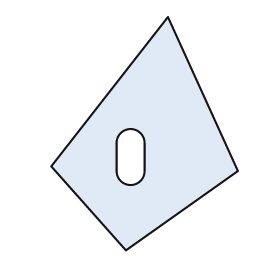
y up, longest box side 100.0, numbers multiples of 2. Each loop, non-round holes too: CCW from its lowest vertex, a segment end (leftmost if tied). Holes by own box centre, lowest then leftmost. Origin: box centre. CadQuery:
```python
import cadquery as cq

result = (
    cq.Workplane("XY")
    .moveTo(-8.0, -50.0)
    .lineTo(40.0, -16.0)
    .lineTo(10.0, 50.0)
    .lineTo(-40.0, -14.0)
    .close()
    .moveTo(-12.0, -16.0)
    .threePointArc((-6.0, -22.0), (0.0, -16.0))
    .lineTo(0.0, -4.0)
    .threePointArc((-6.0, 2.0), (-12.0, -4.0))
    .close()
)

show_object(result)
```